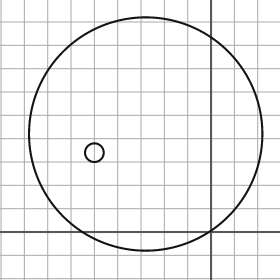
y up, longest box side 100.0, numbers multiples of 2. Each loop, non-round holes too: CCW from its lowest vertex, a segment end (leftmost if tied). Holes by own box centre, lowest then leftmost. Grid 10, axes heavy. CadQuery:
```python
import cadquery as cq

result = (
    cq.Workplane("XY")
    .moveTo(-28.0, 42.0)
    .circle(50.0)
    .moveTo(-50.0, 34.0)
    .circle(4.0)
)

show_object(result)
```